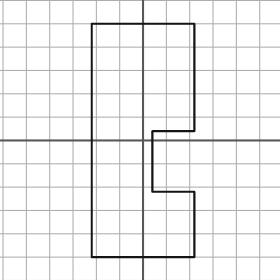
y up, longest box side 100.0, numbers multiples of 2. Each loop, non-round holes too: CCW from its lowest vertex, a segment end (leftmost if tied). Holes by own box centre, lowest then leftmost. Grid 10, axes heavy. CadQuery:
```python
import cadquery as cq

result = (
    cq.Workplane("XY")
    .moveTo(-22.0, -50.0)
    .lineTo(22.0, -50.0)
    .lineTo(22.0, -22.0)
    .lineTo(4.0, -22.0)
    .lineTo(4.0, 4.0)
    .lineTo(22.0, 4.0)
    .lineTo(22.0, 50.0)
    .lineTo(-22.0, 50.0)
    .close()
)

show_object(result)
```